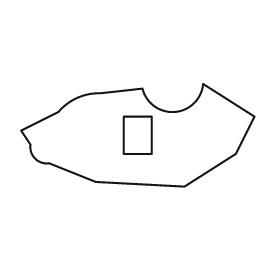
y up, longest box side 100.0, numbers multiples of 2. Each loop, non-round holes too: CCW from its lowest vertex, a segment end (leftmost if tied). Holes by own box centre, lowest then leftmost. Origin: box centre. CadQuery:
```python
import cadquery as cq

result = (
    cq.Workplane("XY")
    .moveTo(20.0, -22.0)
    .lineTo(42.0, -8.0)
    .lineTo(50.0, 8.0)
    .lineTo(28.0, 22.0)
    .threePointArc((16.0, 10.0), (2.0, 20.0))
    .lineTo(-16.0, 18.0)
    .threePointArc((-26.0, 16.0), (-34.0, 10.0))
    .lineTo(-50.0, 2.0)
    .lineTo(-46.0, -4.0)
    .threePointArc((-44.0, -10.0), (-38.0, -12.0))
    .lineTo(-18.0, -20.0)
    .close()
    .moveTo(-6.0, -8.0)
    .lineTo(6.0, -8.0)
    .lineTo(6.0, 8.0)
    .lineTo(-6.0, 8.0)
    .close()
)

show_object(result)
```